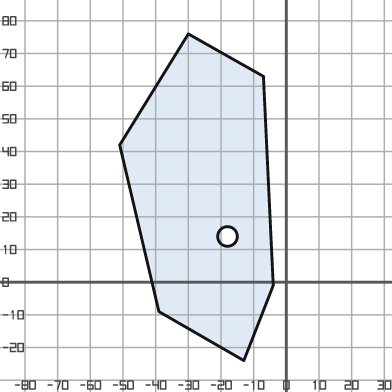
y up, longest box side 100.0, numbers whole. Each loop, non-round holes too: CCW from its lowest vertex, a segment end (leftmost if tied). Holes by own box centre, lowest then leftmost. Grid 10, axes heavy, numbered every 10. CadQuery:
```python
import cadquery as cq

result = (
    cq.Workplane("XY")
    .moveTo(-13.0, -24.0)
    .lineTo(-4.0, -1.0)
    .lineTo(-7.0, 63.0)
    .lineTo(-30.0, 76.0)
    .lineTo(-51.0, 42.0)
    .lineTo(-39.0, -9.0)
    .close()
    .moveTo(-18.0, 14.0)
    .circle(3.0)
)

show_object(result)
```